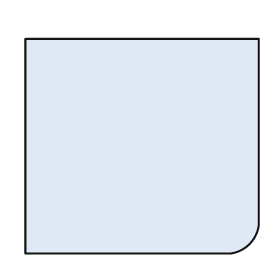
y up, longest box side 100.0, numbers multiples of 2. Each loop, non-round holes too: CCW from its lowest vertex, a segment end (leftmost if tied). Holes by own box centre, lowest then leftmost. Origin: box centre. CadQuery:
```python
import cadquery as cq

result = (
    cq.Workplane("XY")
    .moveTo(-50.0, -46.0)
    .lineTo(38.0, -46.0)
    .threePointArc((46.0, -42.0), (50.0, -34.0))
    .lineTo(50.0, 46.0)
    .lineTo(-50.0, 46.0)
    .close()
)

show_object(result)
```